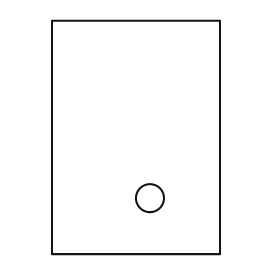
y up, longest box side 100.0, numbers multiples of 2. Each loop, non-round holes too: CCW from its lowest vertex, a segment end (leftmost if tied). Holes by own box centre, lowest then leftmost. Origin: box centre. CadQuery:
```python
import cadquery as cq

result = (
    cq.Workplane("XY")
    .moveTo(-36.0, -50.0)
    .lineTo(36.0, -50.0)
    .lineTo(36.0, 50.0)
    .lineTo(-36.0, 50.0)
    .close()
    .moveTo(6.0, -26.0)
    .circle(6.0)
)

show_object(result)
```